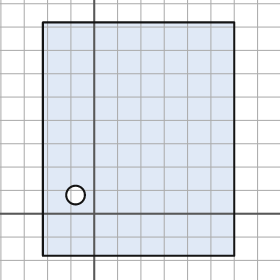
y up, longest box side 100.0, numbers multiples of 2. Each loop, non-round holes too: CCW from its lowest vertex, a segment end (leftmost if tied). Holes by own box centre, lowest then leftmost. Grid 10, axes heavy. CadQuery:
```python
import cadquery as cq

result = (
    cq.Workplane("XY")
    .moveTo(-22.0, -18.0)
    .lineTo(60.0, -18.0)
    .lineTo(60.0, 82.0)
    .lineTo(-22.0, 82.0)
    .close()
    .moveTo(-8.0, 8.0)
    .circle(4.0)
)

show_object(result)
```